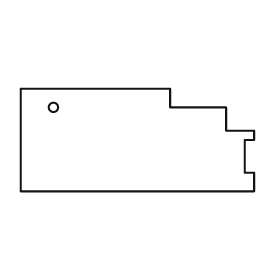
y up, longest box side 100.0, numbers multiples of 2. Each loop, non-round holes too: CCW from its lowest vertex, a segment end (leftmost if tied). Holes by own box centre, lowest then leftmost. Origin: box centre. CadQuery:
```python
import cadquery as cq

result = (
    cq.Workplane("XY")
    .moveTo(-50.0, -22.0)
    .lineTo(50.0, -22.0)
    .lineTo(50.0, -14.0)
    .lineTo(46.0, -14.0)
    .lineTo(46.0, 0.0)
    .lineTo(50.0, 0.0)
    .lineTo(50.0, 4.0)
    .lineTo(38.0, 4.0)
    .lineTo(38.0, 14.0)
    .lineTo(14.0, 14.0)
    .lineTo(14.0, 22.0)
    .lineTo(-50.0, 22.0)
    .close()
    .moveTo(-36.0, 14.0)
    .circle(2.0)
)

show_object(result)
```